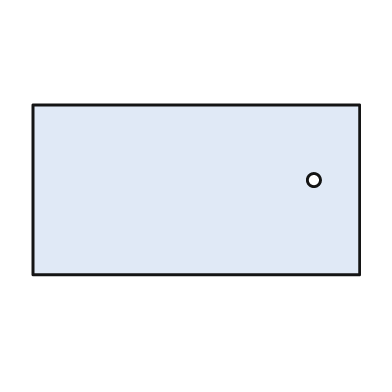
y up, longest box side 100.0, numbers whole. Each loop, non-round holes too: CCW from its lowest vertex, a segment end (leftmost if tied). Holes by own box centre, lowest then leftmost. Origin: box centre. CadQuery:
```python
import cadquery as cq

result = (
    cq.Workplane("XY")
    .moveTo(-50.0, -26.0)
    .lineTo(50.0, -26.0)
    .lineTo(50.0, 26.0)
    .lineTo(-50.0, 26.0)
    .close()
    .moveTo(36.0, 3.0)
    .circle(2.0)
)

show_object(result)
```